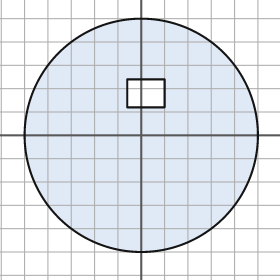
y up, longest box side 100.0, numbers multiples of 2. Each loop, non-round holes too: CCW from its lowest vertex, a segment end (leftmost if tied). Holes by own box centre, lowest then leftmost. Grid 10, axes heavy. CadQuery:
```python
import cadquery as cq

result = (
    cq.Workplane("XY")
    .moveTo(0.0, 0.0)
    .circle(50.0)
    .moveTo(-6.0, 12.0)
    .lineTo(10.0, 12.0)
    .lineTo(10.0, 24.0)
    .lineTo(-6.0, 24.0)
    .close()
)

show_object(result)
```